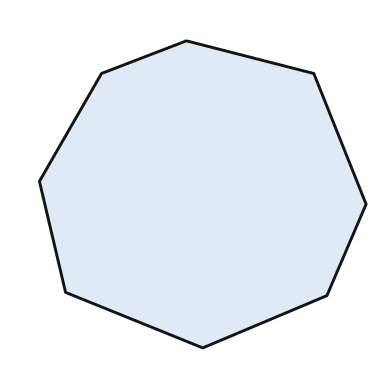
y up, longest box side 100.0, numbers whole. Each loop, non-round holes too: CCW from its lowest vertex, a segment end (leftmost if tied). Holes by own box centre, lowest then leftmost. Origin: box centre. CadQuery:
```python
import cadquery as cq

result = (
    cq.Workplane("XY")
    .moveTo(0.0, -47.0)
    .lineTo(38.0, -31.0)
    .lineTo(50.0, -3.0)
    .lineTo(34.0, 37.0)
    .lineTo(-5.0, 47.0)
    .lineTo(-31.0, 37.0)
    .lineTo(-50.0, 4.0)
    .lineTo(-42.0, -30.0)
    .close()
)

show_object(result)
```